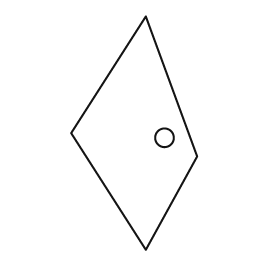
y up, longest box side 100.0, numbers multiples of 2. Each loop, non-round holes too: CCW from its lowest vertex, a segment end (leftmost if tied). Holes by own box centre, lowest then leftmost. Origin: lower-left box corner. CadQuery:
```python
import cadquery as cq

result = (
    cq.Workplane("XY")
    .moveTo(32.0, 0.0)
    .lineTo(54.0, 40.0)
    .lineTo(32.0, 100.0)
    .lineTo(0.0, 50.0)
    .close()
    .moveTo(40.0, 48.0)
    .circle(4.0)
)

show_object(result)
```